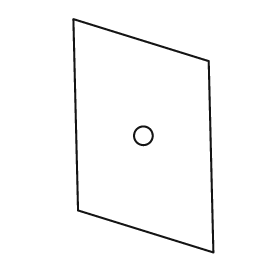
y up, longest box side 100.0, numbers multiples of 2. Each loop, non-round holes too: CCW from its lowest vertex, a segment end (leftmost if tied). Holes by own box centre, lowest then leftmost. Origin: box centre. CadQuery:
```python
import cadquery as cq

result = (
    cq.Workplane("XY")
    .moveTo(30.0, -50.0)
    .lineTo(28.0, 32.0)
    .lineTo(-30.0, 50.0)
    .lineTo(-28.0, -32.0)
    .close()
    .moveTo(0.0, 0.0)
    .circle(4.0)
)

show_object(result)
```